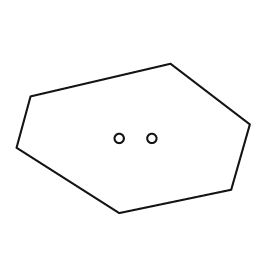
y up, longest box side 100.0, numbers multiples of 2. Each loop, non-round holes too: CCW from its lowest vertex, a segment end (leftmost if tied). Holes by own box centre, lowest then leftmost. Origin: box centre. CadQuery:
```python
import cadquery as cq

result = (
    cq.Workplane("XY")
    .moveTo(-6.0, -32.0)
    .lineTo(42.0, -22.0)
    .lineTo(50.0, 6.0)
    .lineTo(16.0, 32.0)
    .lineTo(-44.0, 18.0)
    .lineTo(-50.0, -4.0)
    .close()
    .moveTo(-6.0, 0.0)
    .circle(2.0)
    .moveTo(8.0, 0.0)
    .circle(2.0)
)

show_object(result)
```